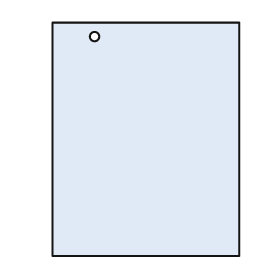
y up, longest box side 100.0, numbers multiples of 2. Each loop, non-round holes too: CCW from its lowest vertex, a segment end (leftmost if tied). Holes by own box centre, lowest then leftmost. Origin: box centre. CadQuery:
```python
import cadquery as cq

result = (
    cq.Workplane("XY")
    .moveTo(-40.0, -50.0)
    .lineTo(40.0, -50.0)
    .lineTo(40.0, 50.0)
    .lineTo(-40.0, 50.0)
    .close()
    .moveTo(-22.0, 44.0)
    .circle(2.0)
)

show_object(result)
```